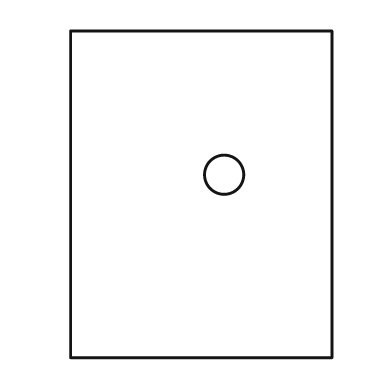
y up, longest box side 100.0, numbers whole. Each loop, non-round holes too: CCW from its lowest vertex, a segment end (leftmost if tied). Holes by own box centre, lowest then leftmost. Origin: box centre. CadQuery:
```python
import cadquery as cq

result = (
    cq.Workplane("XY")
    .moveTo(-40.0, -50.0)
    .lineTo(40.0, -50.0)
    .lineTo(40.0, 50.0)
    .lineTo(-40.0, 50.0)
    .close()
    .moveTo(7.0, 6.0)
    .circle(6.0)
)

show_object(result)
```